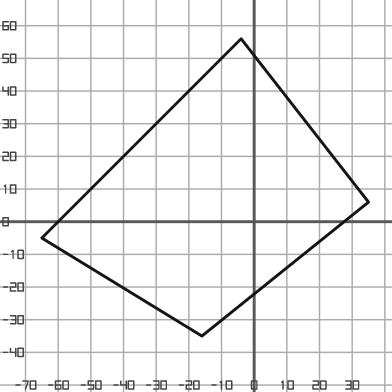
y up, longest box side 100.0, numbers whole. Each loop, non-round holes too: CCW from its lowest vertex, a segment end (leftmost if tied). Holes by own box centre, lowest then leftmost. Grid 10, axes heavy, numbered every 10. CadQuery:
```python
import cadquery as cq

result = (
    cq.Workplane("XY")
    .moveTo(-16.0, -35.0)
    .lineTo(35.0, 6.0)
    .lineTo(-4.0, 56.0)
    .lineTo(-65.0, -5.0)
    .close()
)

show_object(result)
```